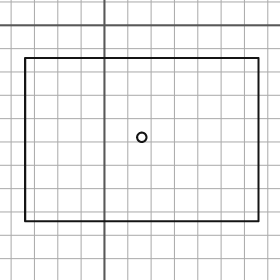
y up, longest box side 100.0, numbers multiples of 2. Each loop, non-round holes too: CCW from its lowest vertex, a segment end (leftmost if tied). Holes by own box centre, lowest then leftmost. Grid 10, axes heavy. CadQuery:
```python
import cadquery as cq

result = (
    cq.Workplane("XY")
    .moveTo(-34.0, -84.0)
    .lineTo(66.0, -84.0)
    .lineTo(66.0, -14.0)
    .lineTo(-34.0, -14.0)
    .close()
    .moveTo(16.0, -48.0)
    .circle(2.0)
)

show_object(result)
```